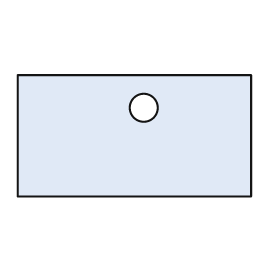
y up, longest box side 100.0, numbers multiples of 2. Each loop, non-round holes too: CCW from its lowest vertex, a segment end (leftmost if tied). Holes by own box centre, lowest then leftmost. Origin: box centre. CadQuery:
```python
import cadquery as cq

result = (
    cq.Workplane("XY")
    .moveTo(-50.0, -26.0)
    .lineTo(50.0, -26.0)
    .lineTo(50.0, 26.0)
    .lineTo(-50.0, 26.0)
    .close()
    .moveTo(4.0, 12.0)
    .circle(6.0)
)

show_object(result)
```